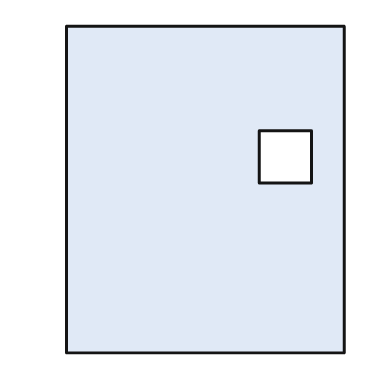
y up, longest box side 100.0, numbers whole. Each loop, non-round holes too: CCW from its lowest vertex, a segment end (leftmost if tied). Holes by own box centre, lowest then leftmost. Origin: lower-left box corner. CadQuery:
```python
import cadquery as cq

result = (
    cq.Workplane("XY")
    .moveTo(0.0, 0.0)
    .lineTo(85.0, 0.0)
    .lineTo(85.0, 100.0)
    .lineTo(0.0, 100.0)
    .close()
    .moveTo(59.0, 52.0)
    .lineTo(75.0, 52.0)
    .lineTo(75.0, 68.0)
    .lineTo(59.0, 68.0)
    .close()
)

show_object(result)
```